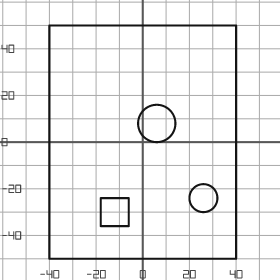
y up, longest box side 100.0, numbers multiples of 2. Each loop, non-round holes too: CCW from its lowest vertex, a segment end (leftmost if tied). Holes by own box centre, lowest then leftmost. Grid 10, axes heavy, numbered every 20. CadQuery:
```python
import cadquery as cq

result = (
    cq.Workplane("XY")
    .moveTo(-40.0, -50.0)
    .lineTo(40.0, -50.0)
    .lineTo(40.0, 50.0)
    .lineTo(-40.0, 50.0)
    .close()
    .moveTo(-18.0, -36.0)
    .lineTo(-6.0, -36.0)
    .lineTo(-6.0, -24.0)
    .lineTo(-18.0, -24.0)
    .close()
    .moveTo(26.0, -24.0)
    .circle(6.0)
    .moveTo(6.0, 8.0)
    .circle(8.0)
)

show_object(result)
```